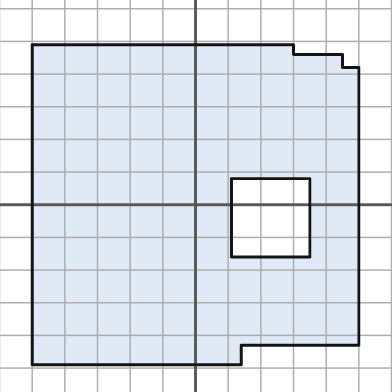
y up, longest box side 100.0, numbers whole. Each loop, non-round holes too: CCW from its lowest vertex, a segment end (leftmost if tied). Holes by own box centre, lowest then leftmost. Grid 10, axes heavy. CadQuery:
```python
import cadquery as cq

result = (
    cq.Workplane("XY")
    .moveTo(-50.0, -49.0)
    .lineTo(14.0, -49.0)
    .lineTo(14.0, -43.0)
    .lineTo(50.0, -43.0)
    .lineTo(50.0, 42.0)
    .lineTo(45.0, 42.0)
    .lineTo(45.0, 46.0)
    .lineTo(30.0, 46.0)
    .lineTo(30.0, 49.0)
    .lineTo(-50.0, 49.0)
    .close()
    .moveTo(11.0, -16.0)
    .lineTo(35.0, -16.0)
    .lineTo(35.0, 8.0)
    .lineTo(11.0, 8.0)
    .close()
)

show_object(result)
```